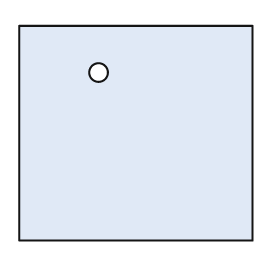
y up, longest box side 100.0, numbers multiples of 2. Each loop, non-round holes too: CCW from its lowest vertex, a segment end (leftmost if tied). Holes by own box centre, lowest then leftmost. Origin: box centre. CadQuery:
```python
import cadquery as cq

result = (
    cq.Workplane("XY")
    .moveTo(-50.0, -46.0)
    .lineTo(50.0, -46.0)
    .lineTo(50.0, 46.0)
    .lineTo(-50.0, 46.0)
    .close()
    .moveTo(-16.0, 26.0)
    .circle(4.0)
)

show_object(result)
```